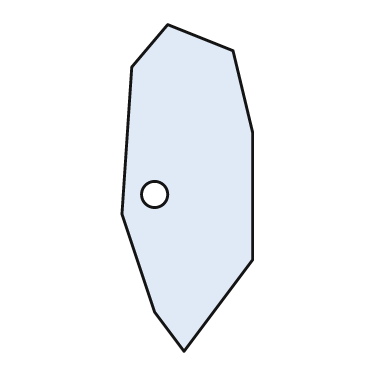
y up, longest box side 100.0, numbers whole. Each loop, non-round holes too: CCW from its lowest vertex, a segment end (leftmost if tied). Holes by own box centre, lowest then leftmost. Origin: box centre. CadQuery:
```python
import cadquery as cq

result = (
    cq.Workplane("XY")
    .moveTo(-1.0, -50.0)
    .lineTo(20.0, -22.0)
    .lineTo(20.0, 17.0)
    .lineTo(14.0, 42.0)
    .lineTo(-6.0, 50.0)
    .lineTo(-17.0, 37.0)
    .lineTo(-20.0, -8.0)
    .lineTo(-10.0, -38.0)
    .close()
    .moveTo(-10.0, -2.0)
    .circle(4.0)
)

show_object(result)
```